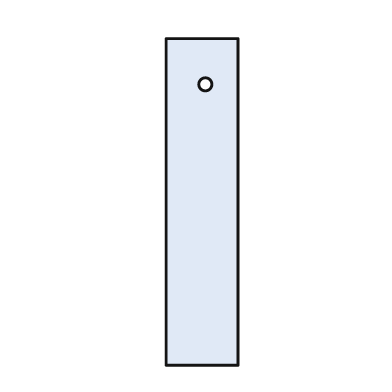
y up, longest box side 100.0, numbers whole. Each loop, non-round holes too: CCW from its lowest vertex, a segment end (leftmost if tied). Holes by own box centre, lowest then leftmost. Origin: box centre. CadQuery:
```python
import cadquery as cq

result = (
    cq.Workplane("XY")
    .moveTo(-11.0, -50.0)
    .lineTo(11.0, -50.0)
    .lineTo(11.0, 50.0)
    .lineTo(-11.0, 50.0)
    .close()
    .moveTo(1.0, 36.0)
    .circle(2.0)
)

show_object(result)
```